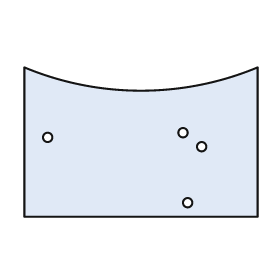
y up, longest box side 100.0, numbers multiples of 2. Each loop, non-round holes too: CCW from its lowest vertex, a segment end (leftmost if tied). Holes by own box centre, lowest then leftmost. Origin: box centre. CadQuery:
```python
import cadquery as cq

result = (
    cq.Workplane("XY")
    .moveTo(-50.0, -32.0)
    .lineTo(50.0, -32.0)
    .lineTo(50.0, 32.0)
    .threePointArc((0.0, 22.0), (-50.0, 32.0))
    .close()
    .moveTo(20.0, -26.0)
    .circle(2.0)
    .moveTo(26.0, -2.0)
    .circle(2.0)
    .moveTo(-40.0, 2.0)
    .circle(2.0)
    .moveTo(18.0, 4.0)
    .circle(2.0)
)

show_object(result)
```